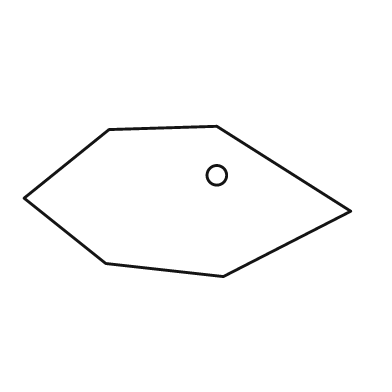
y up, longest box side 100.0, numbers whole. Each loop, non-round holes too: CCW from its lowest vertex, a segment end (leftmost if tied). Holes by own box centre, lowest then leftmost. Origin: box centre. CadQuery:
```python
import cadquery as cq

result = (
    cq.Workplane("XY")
    .moveTo(11.0, -23.0)
    .lineTo(50.0, -3.0)
    .lineTo(9.0, 23.0)
    .lineTo(-24.0, 22.0)
    .lineTo(-50.0, 1.0)
    .lineTo(-25.0, -19.0)
    .close()
    .moveTo(9.0, 8.0)
    .circle(3.0)
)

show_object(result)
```